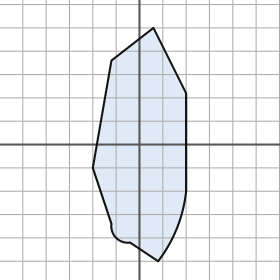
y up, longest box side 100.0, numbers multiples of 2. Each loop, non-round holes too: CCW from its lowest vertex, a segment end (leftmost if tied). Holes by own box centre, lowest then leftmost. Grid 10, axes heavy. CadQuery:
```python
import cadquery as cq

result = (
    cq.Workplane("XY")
    .moveTo(8.0, -50.0)
    .threePointArc((16.0, -36.0), (20.0, -20.0))
    .lineTo(20.0, 22.0)
    .lineTo(6.0, 50.0)
    .lineTo(-12.0, 36.0)
    .lineTo(-20.0, -10.0)
    .lineTo(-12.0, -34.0)
    .threePointArc((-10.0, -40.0), (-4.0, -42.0))
    .close()
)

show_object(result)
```